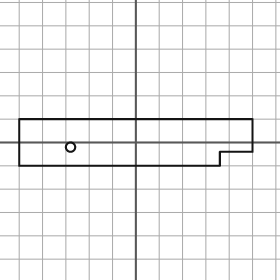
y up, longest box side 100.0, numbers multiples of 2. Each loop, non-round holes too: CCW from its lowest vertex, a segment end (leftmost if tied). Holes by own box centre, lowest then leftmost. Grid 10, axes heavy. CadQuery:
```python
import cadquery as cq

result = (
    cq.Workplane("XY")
    .moveTo(-50.0, -10.0)
    .lineTo(36.0, -10.0)
    .lineTo(36.0, -4.0)
    .lineTo(50.0, -4.0)
    .lineTo(50.0, 10.0)
    .lineTo(-50.0, 10.0)
    .close()
    .moveTo(-28.0, -2.0)
    .circle(2.0)
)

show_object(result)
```